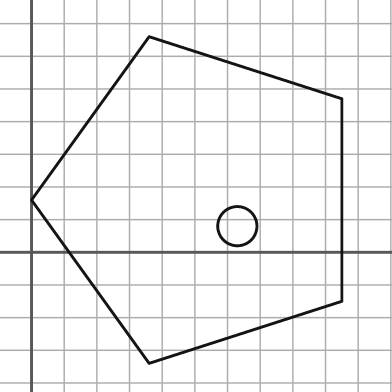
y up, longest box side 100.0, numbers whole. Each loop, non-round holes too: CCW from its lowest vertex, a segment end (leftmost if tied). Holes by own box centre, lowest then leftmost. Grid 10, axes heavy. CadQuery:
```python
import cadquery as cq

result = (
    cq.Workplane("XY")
    .moveTo(36.0, -34.0)
    .lineTo(95.0, -15.0)
    .lineTo(95.0, 47.0)
    .lineTo(36.0, 66.0)
    .lineTo(0.0, 16.0)
    .close()
    .moveTo(63.0, 8.0)
    .circle(6.0)
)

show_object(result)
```